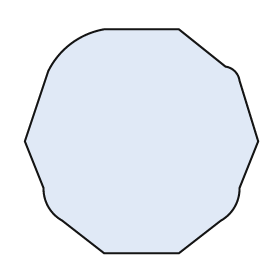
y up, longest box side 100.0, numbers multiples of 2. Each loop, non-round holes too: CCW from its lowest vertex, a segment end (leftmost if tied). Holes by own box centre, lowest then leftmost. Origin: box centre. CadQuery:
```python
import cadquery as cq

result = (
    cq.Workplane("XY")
    .moveTo(-16.0, -48.0)
    .lineTo(16.0, -48.0)
    .lineTo(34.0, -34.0)
    .threePointArc((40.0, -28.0), (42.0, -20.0))
    .lineTo(50.0, 0.0)
    .lineTo(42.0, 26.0)
    .threePointArc((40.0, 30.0), (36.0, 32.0))
    .lineTo(16.0, 48.0)
    .lineTo(-16.0, 48.0)
    .threePointArc((-30.0, 42.0), (-40.0, 30.0))
    .lineTo(-50.0, 0.0)
    .lineTo(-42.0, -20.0)
    .threePointArc((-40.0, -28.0), (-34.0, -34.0))
    .close()
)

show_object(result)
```